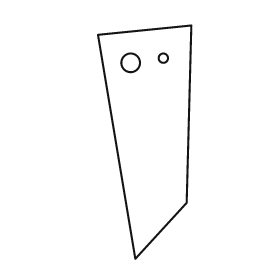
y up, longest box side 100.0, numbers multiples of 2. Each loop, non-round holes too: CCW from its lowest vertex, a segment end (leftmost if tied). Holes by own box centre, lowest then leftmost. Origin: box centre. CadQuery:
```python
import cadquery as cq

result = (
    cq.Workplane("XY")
    .moveTo(-4.0, -50.0)
    .lineTo(18.0, -26.0)
    .lineTo(20.0, 50.0)
    .lineTo(-20.0, 46.0)
    .close()
    .moveTo(-6.0, 34.0)
    .circle(4.0)
    .moveTo(8.0, 36.0)
    .circle(2.0)
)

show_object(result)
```